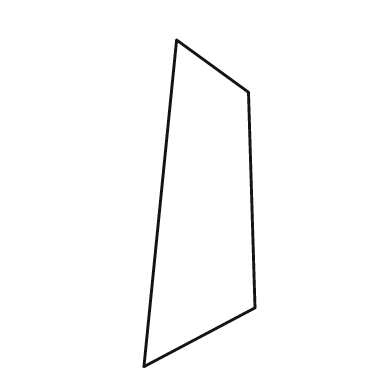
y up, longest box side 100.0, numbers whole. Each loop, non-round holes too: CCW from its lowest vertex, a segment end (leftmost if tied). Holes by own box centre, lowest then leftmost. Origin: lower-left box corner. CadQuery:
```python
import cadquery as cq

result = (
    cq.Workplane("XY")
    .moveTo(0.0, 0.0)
    .lineTo(34.0, 18.0)
    .lineTo(32.0, 84.0)
    .lineTo(10.0, 100.0)
    .close()
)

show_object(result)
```